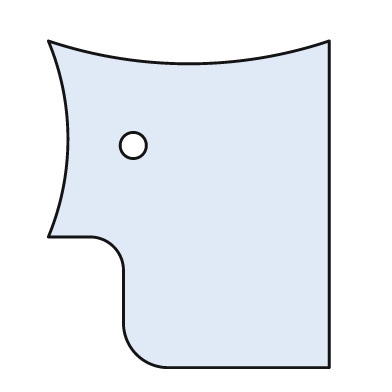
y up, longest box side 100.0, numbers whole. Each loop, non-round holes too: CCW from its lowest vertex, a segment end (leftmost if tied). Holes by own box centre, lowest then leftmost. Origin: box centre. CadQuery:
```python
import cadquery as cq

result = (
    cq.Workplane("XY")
    .moveTo(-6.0, -50.0)
    .lineTo(43.0, -50.0)
    .lineTo(43.0, 50.0)
    .threePointArc((0.0, 43.0), (-43.0, 50.0))
    .threePointArc((-37.0, 20.0), (-43.0, -10.0))
    .lineTo(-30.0, -10.0)
    .threePointArc((-23.0, -13.0), (-20.0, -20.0))
    .lineTo(-20.0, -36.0)
    .threePointArc((-16.0, -46.0), (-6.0, -50.0))
    .close()
    .moveTo(-17.0, 18.0)
    .circle(4.0)
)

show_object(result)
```